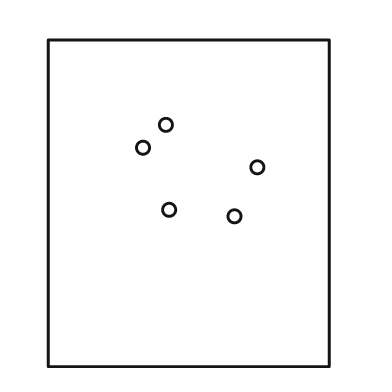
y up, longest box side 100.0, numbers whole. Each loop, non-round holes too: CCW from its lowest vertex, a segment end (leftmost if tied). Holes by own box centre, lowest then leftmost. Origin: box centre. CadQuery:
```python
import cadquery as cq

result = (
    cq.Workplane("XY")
    .moveTo(-43.0, -50.0)
    .lineTo(43.0, -50.0)
    .lineTo(43.0, 50.0)
    .lineTo(-43.0, 50.0)
    .close()
    .moveTo(14.0, -4.0)
    .circle(2.0)
    .moveTo(-6.0, -2.0)
    .circle(2.0)
    .moveTo(21.0, 11.0)
    .circle(2.0)
    .moveTo(-14.0, 17.0)
    .circle(2.0)
    .moveTo(-7.0, 24.0)
    .circle(2.0)
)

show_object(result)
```